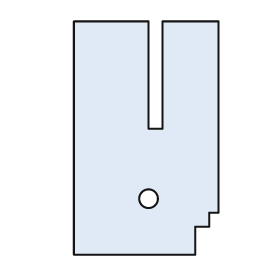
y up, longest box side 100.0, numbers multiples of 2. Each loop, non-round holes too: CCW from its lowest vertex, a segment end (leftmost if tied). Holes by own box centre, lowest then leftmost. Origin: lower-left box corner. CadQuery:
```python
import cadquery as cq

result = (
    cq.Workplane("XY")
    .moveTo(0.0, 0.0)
    .lineTo(52.0, 0.0)
    .lineTo(52.0, 12.0)
    .lineTo(58.0, 12.0)
    .lineTo(58.0, 18.0)
    .lineTo(62.0, 18.0)
    .lineTo(62.0, 100.0)
    .lineTo(38.0, 100.0)
    .lineTo(38.0, 54.0)
    .lineTo(32.0, 54.0)
    .lineTo(32.0, 100.0)
    .lineTo(0.0, 100.0)
    .close()
    .moveTo(32.0, 24.0)
    .circle(4.0)
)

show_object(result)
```